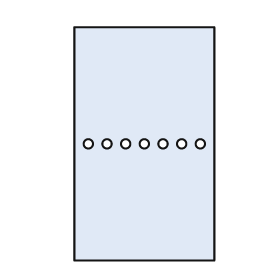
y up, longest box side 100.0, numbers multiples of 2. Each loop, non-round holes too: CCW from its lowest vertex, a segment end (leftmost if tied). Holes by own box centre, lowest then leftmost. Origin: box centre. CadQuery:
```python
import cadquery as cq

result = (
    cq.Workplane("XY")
    .moveTo(-30.0, -50.0)
    .lineTo(30.0, -50.0)
    .lineTo(30.0, 50.0)
    .lineTo(-30.0, 50.0)
    .close()
    .moveTo(-24.0, 0.0)
    .circle(2.0)
    .moveTo(-16.0, 0.0)
    .circle(2.0)
    .moveTo(-8.0, 0.0)
    .circle(2.0)
    .moveTo(0.0, 0.0)
    .circle(2.0)
    .moveTo(8.0, 0.0)
    .circle(2.0)
    .moveTo(16.0, 0.0)
    .circle(2.0)
    .moveTo(24.0, 0.0)
    .circle(2.0)
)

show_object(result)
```